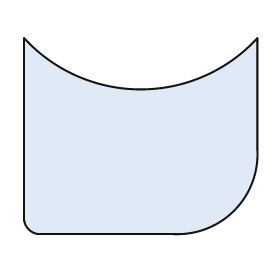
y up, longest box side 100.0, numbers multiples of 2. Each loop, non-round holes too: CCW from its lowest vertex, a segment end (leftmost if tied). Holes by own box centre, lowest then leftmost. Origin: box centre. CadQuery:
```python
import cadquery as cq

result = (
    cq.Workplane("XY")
    .moveTo(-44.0, -42.0)
    .lineTo(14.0, -42.0)
    .threePointArc((40.0, -32.0), (50.0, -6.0))
    .lineTo(50.0, 42.0)
    .threePointArc((0.0, 20.0), (-50.0, 42.0))
    .lineTo(-50.0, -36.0)
    .threePointArc((-48.0, -40.0), (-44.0, -42.0))
    .close()
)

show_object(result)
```